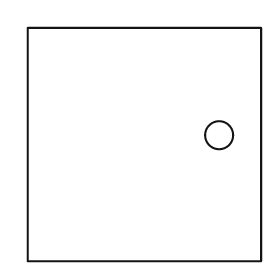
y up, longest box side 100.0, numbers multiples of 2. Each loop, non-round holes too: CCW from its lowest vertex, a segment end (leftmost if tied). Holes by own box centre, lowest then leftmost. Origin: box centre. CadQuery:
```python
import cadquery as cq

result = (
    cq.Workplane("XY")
    .moveTo(-50.0, -50.0)
    .lineTo(50.0, -50.0)
    .lineTo(50.0, 50.0)
    .lineTo(-50.0, 50.0)
    .close()
    .moveTo(32.0, 4.0)
    .circle(6.0)
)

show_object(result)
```